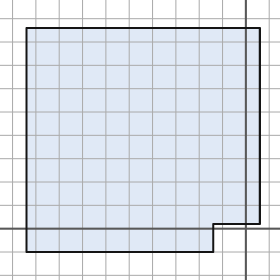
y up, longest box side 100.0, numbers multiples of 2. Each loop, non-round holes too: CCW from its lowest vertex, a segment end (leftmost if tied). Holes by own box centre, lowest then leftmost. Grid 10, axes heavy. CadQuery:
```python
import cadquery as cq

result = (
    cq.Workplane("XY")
    .moveTo(-94.0, -10.0)
    .lineTo(-14.0, -10.0)
    .lineTo(-14.0, 2.0)
    .lineTo(6.0, 2.0)
    .lineTo(6.0, 86.0)
    .lineTo(-94.0, 86.0)
    .close()
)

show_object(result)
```